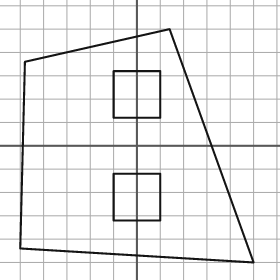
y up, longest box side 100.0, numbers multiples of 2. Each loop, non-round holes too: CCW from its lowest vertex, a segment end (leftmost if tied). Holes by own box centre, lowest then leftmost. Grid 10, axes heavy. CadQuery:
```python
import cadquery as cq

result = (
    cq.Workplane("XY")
    .moveTo(50.0, -50.0)
    .lineTo(14.0, 50.0)
    .lineTo(-48.0, 36.0)
    .lineTo(-50.0, -44.0)
    .close()
    .moveTo(-10.0, -32.0)
    .lineTo(10.0, -32.0)
    .lineTo(10.0, -12.0)
    .lineTo(-10.0, -12.0)
    .close()
    .moveTo(-10.0, 12.0)
    .lineTo(10.0, 12.0)
    .lineTo(10.0, 32.0)
    .lineTo(-10.0, 32.0)
    .close()
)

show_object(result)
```